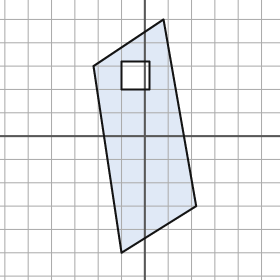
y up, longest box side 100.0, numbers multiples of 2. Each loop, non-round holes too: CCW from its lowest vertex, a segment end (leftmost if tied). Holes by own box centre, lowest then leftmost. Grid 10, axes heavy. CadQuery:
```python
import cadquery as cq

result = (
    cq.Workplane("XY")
    .moveTo(-10.0, -50.0)
    .lineTo(22.0, -30.0)
    .lineTo(8.0, 50.0)
    .lineTo(-22.0, 30.0)
    .close()
    .moveTo(-10.0, 20.0)
    .lineTo(2.0, 20.0)
    .lineTo(2.0, 32.0)
    .lineTo(-10.0, 32.0)
    .close()
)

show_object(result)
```